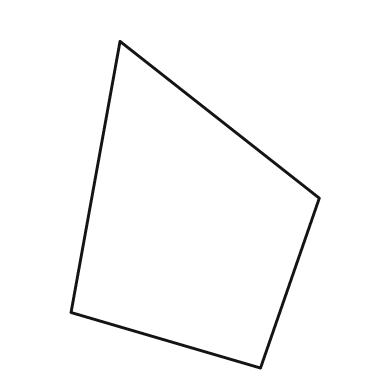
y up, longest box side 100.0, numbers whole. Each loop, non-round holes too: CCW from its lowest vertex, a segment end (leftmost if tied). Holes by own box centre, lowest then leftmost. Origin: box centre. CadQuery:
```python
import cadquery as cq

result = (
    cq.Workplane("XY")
    .moveTo(20.0, -50.0)
    .lineTo(38.0, 2.0)
    .lineTo(-23.0, 50.0)
    .lineTo(-38.0, -33.0)
    .close()
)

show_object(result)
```